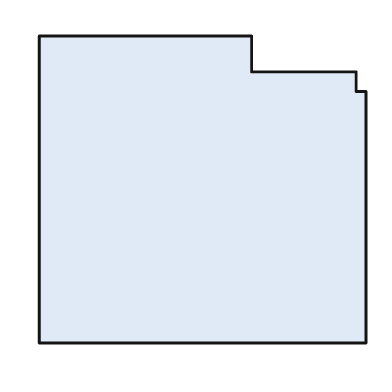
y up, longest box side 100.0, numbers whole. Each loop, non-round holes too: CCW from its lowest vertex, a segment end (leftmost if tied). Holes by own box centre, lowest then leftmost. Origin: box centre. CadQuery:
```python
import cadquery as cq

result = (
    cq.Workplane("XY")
    .moveTo(-50.0, -47.0)
    .lineTo(50.0, -47.0)
    .lineTo(50.0, 30.0)
    .lineTo(47.0, 30.0)
    .lineTo(47.0, 36.0)
    .lineTo(15.0, 36.0)
    .lineTo(15.0, 47.0)
    .lineTo(-50.0, 47.0)
    .close()
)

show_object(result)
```